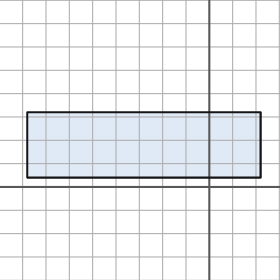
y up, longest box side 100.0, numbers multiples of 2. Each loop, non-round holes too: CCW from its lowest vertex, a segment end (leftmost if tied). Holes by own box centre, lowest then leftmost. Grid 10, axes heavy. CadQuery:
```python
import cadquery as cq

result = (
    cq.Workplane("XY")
    .moveTo(-78.0, 4.0)
    .lineTo(22.0, 4.0)
    .lineTo(22.0, 32.0)
    .lineTo(-78.0, 32.0)
    .close()
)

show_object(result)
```